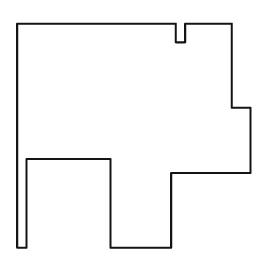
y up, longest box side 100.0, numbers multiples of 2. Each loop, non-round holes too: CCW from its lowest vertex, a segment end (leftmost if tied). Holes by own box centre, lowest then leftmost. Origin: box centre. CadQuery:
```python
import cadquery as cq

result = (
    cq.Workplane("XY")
    .moveTo(-50.0, -48.0)
    .lineTo(-46.0, -48.0)
    .lineTo(-46.0, -10.0)
    .lineTo(-10.0, -10.0)
    .lineTo(-10.0, -48.0)
    .lineTo(16.0, -48.0)
    .lineTo(16.0, -16.0)
    .lineTo(50.0, -16.0)
    .lineTo(50.0, 12.0)
    .lineTo(42.0, 12.0)
    .lineTo(42.0, 48.0)
    .lineTo(22.0, 48.0)
    .lineTo(22.0, 40.0)
    .lineTo(18.0, 40.0)
    .lineTo(18.0, 48.0)
    .lineTo(-50.0, 48.0)
    .close()
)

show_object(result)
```